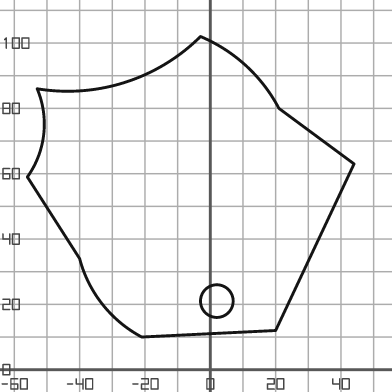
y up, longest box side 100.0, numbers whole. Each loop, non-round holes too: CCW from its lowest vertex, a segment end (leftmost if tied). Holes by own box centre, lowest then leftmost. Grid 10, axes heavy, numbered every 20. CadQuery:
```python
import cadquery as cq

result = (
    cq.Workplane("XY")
    .moveTo(-21.0, 10.0)
    .lineTo(20.0, 12.0)
    .lineTo(44.0, 63.0)
    .lineTo(21.0, 80.0)
    .threePointArc((11.0, 93.0), (-3.0, 102.0))
    .threePointArc((-26.0, 88.0), (-53.0, 86.0))
    .threePointArc((-51.0, 72.0), (-56.0, 59.0))
    .lineTo(-40.0, 34.0)
    .threePointArc((-33.0, 20.0), (-21.0, 10.0))
    .close()
    .moveTo(2.0, 21.0)
    .circle(5.0)
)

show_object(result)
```